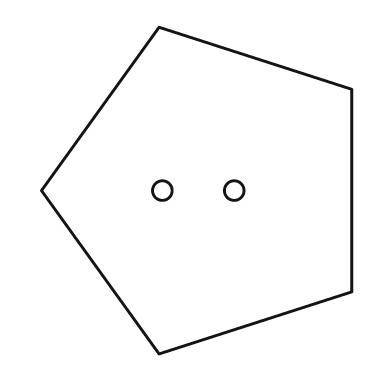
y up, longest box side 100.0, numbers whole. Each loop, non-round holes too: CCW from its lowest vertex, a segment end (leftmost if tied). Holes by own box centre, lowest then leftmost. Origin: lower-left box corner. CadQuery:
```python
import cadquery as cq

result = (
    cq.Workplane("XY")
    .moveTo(36.0, 0.0)
    .lineTo(95.0, 19.0)
    .lineTo(95.0, 81.0)
    .lineTo(36.0, 100.0)
    .lineTo(0.0, 50.0)
    .close()
    .moveTo(37.0, 50.0)
    .circle(3.0)
    .moveTo(59.0, 50.0)
    .circle(3.0)
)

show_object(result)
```